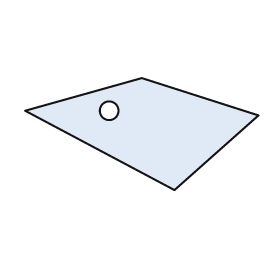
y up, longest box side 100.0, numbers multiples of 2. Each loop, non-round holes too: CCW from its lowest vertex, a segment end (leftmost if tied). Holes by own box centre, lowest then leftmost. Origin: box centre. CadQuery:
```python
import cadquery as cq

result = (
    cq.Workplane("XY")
    .moveTo(14.0, -24.0)
    .lineTo(50.0, 8.0)
    .lineTo(0.0, 24.0)
    .lineTo(-50.0, 10.0)
    .close()
    .moveTo(-14.0, 10.0)
    .circle(4.0)
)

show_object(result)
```